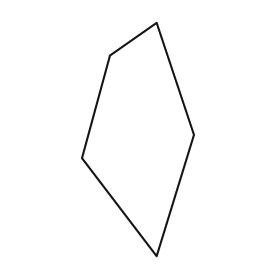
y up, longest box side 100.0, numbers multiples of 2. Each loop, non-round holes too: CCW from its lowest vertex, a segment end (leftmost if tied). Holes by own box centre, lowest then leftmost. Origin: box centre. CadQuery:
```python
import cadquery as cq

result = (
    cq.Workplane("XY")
    .moveTo(8.0, -50.0)
    .lineTo(24.0, 2.0)
    .lineTo(8.0, 50.0)
    .lineTo(-12.0, 36.0)
    .lineTo(-24.0, -8.0)
    .close()
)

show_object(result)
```